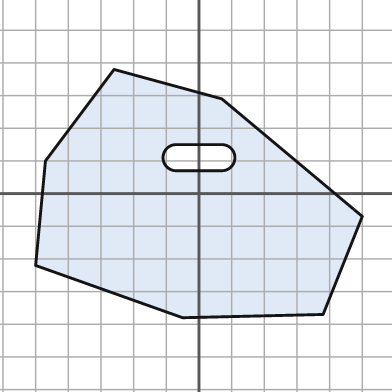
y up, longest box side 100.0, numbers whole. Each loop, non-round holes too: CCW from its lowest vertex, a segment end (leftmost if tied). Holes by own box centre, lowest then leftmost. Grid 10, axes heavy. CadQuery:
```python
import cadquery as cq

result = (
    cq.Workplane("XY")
    .moveTo(-5.0, -38.0)
    .lineTo(38.0, -37.0)
    .lineTo(50.0, -7.0)
    .lineTo(7.0, 29.0)
    .lineTo(-26.0, 38.0)
    .lineTo(-47.0, 10.0)
    .lineTo(-50.0, -22.0)
    .close()
    .moveTo(-7.0, 7.0)
    .lineTo(7.0, 7.0)
    .threePointArc((11.0, 11.0), (7.0, 15.0))
    .lineTo(-7.0, 15.0)
    .threePointArc((-11.0, 11.0), (-7.0, 7.0))
    .close()
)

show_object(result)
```